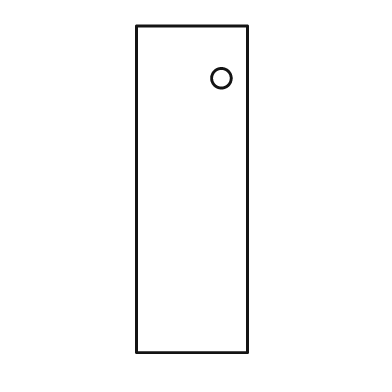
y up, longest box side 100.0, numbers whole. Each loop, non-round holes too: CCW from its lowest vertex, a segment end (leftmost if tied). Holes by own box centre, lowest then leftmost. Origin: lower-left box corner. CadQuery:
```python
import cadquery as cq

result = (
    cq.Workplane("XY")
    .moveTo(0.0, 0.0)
    .lineTo(34.0, 0.0)
    .lineTo(34.0, 100.0)
    .lineTo(0.0, 100.0)
    .close()
    .moveTo(26.0, 84.0)
    .circle(3.0)
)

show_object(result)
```